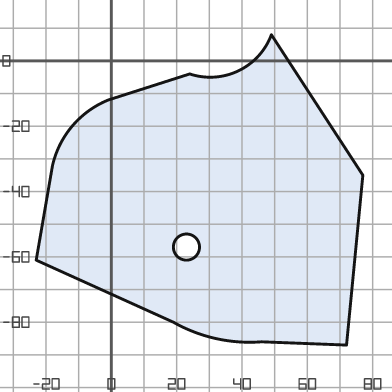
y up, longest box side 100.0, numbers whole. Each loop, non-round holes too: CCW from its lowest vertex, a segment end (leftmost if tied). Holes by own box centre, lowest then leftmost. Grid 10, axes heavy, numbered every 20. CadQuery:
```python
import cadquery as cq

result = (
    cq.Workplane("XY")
    .moveTo(72.0, -87.0)
    .lineTo(77.0, -35.0)
    .lineTo(49.0, 8.0)
    .threePointArc((39.0, -3.0), (24.0, -4.0))
    .lineTo(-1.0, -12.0)
    .threePointArc((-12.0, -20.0), (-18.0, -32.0))
    .lineTo(-23.0, -61.0)
    .lineTo(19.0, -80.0)
    .threePointArc((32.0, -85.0), (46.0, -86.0))
    .close()
    .moveTo(23.0, -57.0)
    .circle(4.0)
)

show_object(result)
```